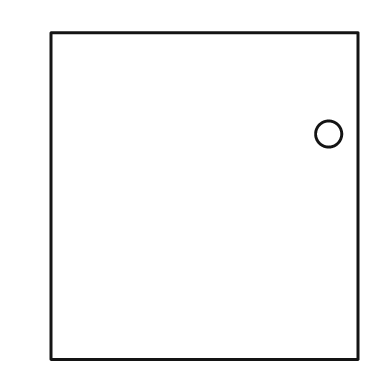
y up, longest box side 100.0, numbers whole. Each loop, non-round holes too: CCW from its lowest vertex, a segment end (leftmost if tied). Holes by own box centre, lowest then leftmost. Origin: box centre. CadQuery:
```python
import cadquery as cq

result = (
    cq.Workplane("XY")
    .moveTo(-47.0, -50.0)
    .lineTo(47.0, -50.0)
    .lineTo(47.0, 50.0)
    .lineTo(-47.0, 50.0)
    .close()
    .moveTo(38.0, 19.0)
    .circle(4.0)
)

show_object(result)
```